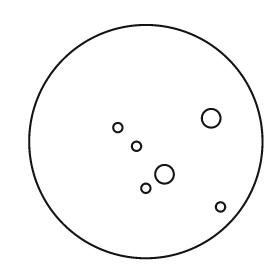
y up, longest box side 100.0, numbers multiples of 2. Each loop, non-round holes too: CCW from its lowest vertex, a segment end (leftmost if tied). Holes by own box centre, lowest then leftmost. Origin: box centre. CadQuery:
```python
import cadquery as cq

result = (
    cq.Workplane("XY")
    .moveTo(0.0, 0.0)
    .circle(50.0)
    .moveTo(32.0, -28.0)
    .circle(2.0)
    .moveTo(0.0, -20.0)
    .circle(2.0)
    .moveTo(8.0, -14.0)
    .circle(4.0)
    .moveTo(-4.0, -2.0)
    .circle(2.0)
    .moveTo(-12.0, 6.0)
    .circle(2.0)
    .moveTo(28.0, 10.0)
    .circle(4.0)
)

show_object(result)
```